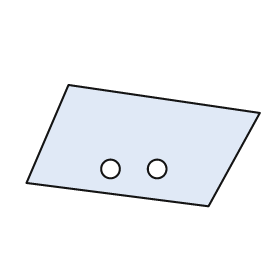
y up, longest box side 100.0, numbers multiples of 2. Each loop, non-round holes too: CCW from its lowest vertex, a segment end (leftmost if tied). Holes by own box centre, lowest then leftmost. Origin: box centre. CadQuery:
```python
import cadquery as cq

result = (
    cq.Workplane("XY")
    .moveTo(28.0, -26.0)
    .lineTo(50.0, 14.0)
    .lineTo(-32.0, 26.0)
    .lineTo(-50.0, -16.0)
    .close()
    .moveTo(-14.0, -10.0)
    .circle(4.0)
    .moveTo(6.0, -10.0)
    .circle(4.0)
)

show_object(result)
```